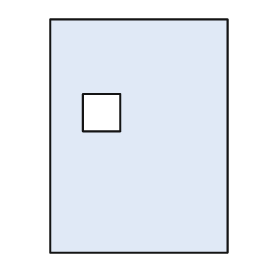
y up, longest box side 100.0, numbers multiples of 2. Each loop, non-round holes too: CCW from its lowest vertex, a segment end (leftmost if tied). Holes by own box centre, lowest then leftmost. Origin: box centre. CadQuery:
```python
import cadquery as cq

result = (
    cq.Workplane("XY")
    .moveTo(-38.0, -50.0)
    .lineTo(38.0, -50.0)
    .lineTo(38.0, 50.0)
    .lineTo(-38.0, 50.0)
    .close()
    .moveTo(-24.0, 2.0)
    .lineTo(-8.0, 2.0)
    .lineTo(-8.0, 18.0)
    .lineTo(-24.0, 18.0)
    .close()
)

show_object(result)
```